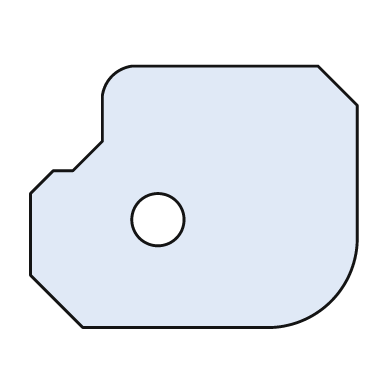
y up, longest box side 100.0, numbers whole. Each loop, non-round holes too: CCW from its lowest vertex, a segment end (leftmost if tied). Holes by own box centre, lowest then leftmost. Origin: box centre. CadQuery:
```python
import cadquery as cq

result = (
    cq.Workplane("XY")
    .moveTo(-34.0, -40.0)
    .lineTo(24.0, -40.0)
    .threePointArc((42.0, -32.0), (50.0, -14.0))
    .lineTo(50.0, 28.0)
    .lineTo(38.0, 40.0)
    .lineTo(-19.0, 40.0)
    .threePointArc((-25.0, 37.0), (-28.0, 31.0))
    .lineTo(-28.0, 17.0)
    .lineTo(-37.0, 8.0)
    .lineTo(-43.0, 8.0)
    .lineTo(-50.0, 1.0)
    .lineTo(-50.0, -24.0)
    .close()
    .moveTo(-11.0, -7.0)
    .circle(8.0)
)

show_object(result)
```